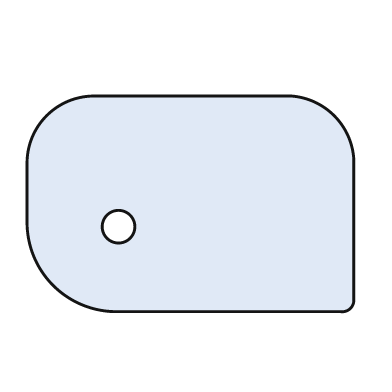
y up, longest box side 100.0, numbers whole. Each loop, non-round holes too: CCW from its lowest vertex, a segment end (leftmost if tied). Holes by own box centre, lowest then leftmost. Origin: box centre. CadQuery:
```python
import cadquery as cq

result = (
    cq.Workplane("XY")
    .moveTo(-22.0, -33.0)
    .lineTo(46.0, -33.0)
    .threePointArc((49.0, -32.0), (50.0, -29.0))
    .lineTo(50.0, 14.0)
    .threePointArc((44.0, 27.0), (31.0, 33.0))
    .lineTo(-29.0, 33.0)
    .threePointArc((-44.0, 27.0), (-50.0, 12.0))
    .lineTo(-50.0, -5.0)
    .threePointArc((-42.0, -25.0), (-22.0, -33.0))
    .close()
    .moveTo(-22.0, -7.0)
    .circle(5.0)
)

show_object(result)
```